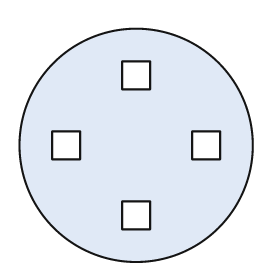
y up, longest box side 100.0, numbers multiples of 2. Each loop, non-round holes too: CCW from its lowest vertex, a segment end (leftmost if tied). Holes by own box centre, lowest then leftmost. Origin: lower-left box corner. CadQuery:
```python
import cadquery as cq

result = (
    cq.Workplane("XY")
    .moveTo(50.0, 50.0)
    .circle(50.0)
    .moveTo(44.0, 14.0)
    .lineTo(56.0, 14.0)
    .lineTo(56.0, 26.0)
    .lineTo(44.0, 26.0)
    .close()
    .moveTo(14.0, 44.0)
    .lineTo(26.0, 44.0)
    .lineTo(26.0, 56.0)
    .lineTo(14.0, 56.0)
    .close()
    .moveTo(74.0, 44.0)
    .lineTo(86.0, 44.0)
    .lineTo(86.0, 56.0)
    .lineTo(74.0, 56.0)
    .close()
    .moveTo(44.0, 74.0)
    .lineTo(56.0, 74.0)
    .lineTo(56.0, 86.0)
    .lineTo(44.0, 86.0)
    .close()
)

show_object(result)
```